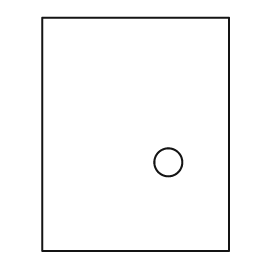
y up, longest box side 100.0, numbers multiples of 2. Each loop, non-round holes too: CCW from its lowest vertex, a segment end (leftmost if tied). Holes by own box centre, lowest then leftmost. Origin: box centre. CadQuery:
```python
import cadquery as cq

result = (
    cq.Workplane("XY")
    .moveTo(-40.0, -50.0)
    .lineTo(40.0, -50.0)
    .lineTo(40.0, 50.0)
    .lineTo(-40.0, 50.0)
    .close()
    .moveTo(14.0, -12.0)
    .circle(6.0)
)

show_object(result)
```